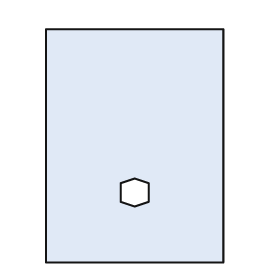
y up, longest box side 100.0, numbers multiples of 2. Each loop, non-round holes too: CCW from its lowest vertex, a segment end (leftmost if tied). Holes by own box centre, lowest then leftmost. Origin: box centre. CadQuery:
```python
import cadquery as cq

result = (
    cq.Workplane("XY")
    .moveTo(-38.0, -50.0)
    .lineTo(38.0, -50.0)
    .lineTo(38.0, 50.0)
    .lineTo(-38.0, 50.0)
    .close()
    .moveTo(0.0, -26.0)
    .lineTo(6.0, -24.0)
    .lineTo(6.0, -16.0)
    .lineTo(0.0, -14.0)
    .lineTo(-6.0, -16.0)
    .lineTo(-6.0, -24.0)
    .close()
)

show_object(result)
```